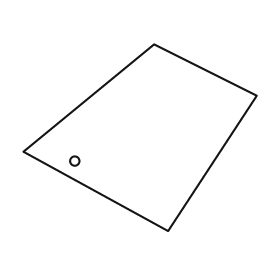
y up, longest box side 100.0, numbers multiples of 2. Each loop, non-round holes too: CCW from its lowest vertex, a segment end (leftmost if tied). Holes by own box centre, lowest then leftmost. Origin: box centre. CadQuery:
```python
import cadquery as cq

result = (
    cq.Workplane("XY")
    .moveTo(12.0, -40.0)
    .lineTo(50.0, 18.0)
    .lineTo(6.0, 40.0)
    .lineTo(-50.0, -6.0)
    .close()
    .moveTo(-28.0, -10.0)
    .circle(2.0)
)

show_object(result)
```